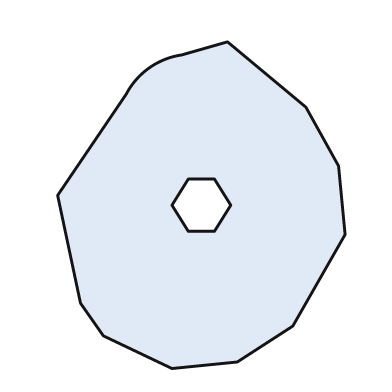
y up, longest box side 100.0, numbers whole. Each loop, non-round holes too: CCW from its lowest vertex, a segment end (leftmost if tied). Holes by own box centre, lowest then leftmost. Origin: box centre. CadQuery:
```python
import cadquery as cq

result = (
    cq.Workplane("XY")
    .moveTo(-9.0, -50.0)
    .lineTo(11.0, -48.0)
    .lineTo(28.0, -37.0)
    .lineTo(44.0, -9.0)
    .lineTo(42.0, 12.0)
    .lineTo(32.0, 30.0)
    .lineTo(8.0, 50.0)
    .lineTo(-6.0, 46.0)
    .threePointArc((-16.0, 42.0), (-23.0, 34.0))
    .lineTo(-44.0, 3.0)
    .lineTo(-37.0, -30.0)
    .lineTo(-30.0, -40.0)
    .close()
    .moveTo(-4.0, -8.0)
    .lineTo(4.0, -8.0)
    .lineTo(9.0, 0.0)
    .lineTo(4.0, 8.0)
    .lineTo(-4.0, 8.0)
    .lineTo(-9.0, 0.0)
    .close()
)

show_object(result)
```